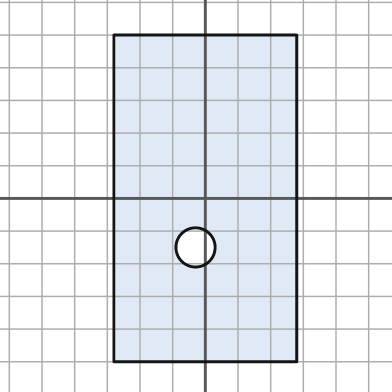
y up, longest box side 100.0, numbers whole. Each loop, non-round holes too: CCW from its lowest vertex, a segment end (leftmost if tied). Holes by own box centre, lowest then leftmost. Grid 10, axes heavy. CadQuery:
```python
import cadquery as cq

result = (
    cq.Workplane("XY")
    .moveTo(-28.0, -50.0)
    .lineTo(28.0, -50.0)
    .lineTo(28.0, 50.0)
    .lineTo(-28.0, 50.0)
    .close()
    .moveTo(-3.0, -15.0)
    .circle(6.0)
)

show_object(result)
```